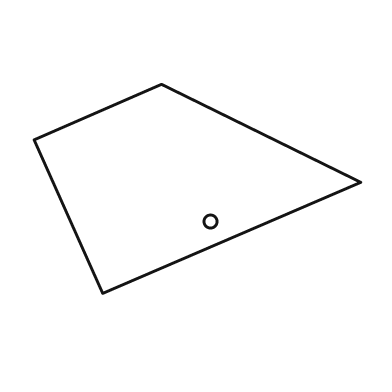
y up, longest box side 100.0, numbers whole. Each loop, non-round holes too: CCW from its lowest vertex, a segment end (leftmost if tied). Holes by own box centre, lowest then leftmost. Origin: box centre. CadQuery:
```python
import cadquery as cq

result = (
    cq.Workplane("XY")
    .moveTo(-29.0, -32.0)
    .lineTo(50.0, 2.0)
    .lineTo(-11.0, 32.0)
    .lineTo(-50.0, 15.0)
    .close()
    .moveTo(4.0, -10.0)
    .circle(2.0)
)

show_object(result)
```